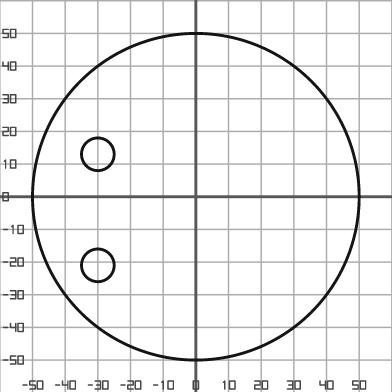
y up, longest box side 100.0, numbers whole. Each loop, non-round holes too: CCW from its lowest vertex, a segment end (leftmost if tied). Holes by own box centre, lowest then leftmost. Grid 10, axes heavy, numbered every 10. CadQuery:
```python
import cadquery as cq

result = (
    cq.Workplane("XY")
    .moveTo(0.0, 0.0)
    .circle(50.0)
    .moveTo(-30.0, -21.0)
    .circle(5.0)
    .moveTo(-30.0, 13.0)
    .circle(5.0)
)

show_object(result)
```